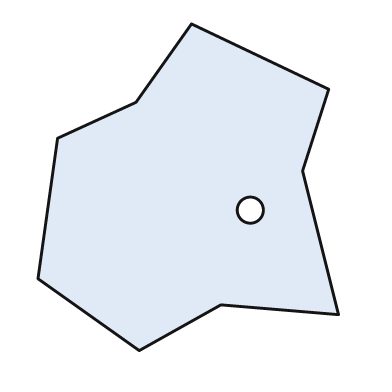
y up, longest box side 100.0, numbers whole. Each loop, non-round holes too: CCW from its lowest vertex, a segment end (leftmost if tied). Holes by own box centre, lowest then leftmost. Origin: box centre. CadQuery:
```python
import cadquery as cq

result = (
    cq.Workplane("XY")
    .moveTo(-15.0, -50.0)
    .lineTo(10.0, -36.0)
    .lineTo(46.0, -39.0)
    .lineTo(35.0, 5.0)
    .lineTo(43.0, 30.0)
    .lineTo(1.0, 50.0)
    .lineTo(-16.0, 26.0)
    .lineTo(-40.0, 15.0)
    .lineTo(-46.0, -28.0)
    .close()
    .moveTo(19.0, -7.0)
    .circle(4.0)
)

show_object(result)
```